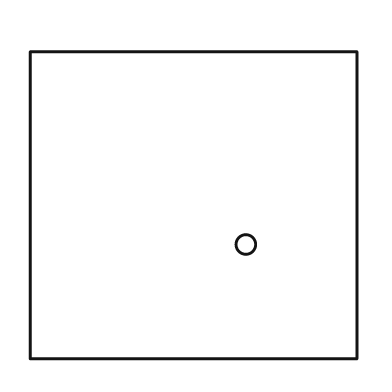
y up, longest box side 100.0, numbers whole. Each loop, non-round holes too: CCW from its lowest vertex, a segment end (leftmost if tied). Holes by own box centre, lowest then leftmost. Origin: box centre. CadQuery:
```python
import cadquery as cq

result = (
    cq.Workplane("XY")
    .moveTo(-50.0, -47.0)
    .lineTo(50.0, -47.0)
    .lineTo(50.0, 47.0)
    .lineTo(-50.0, 47.0)
    .close()
    .moveTo(16.0, -12.0)
    .circle(3.0)
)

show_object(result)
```